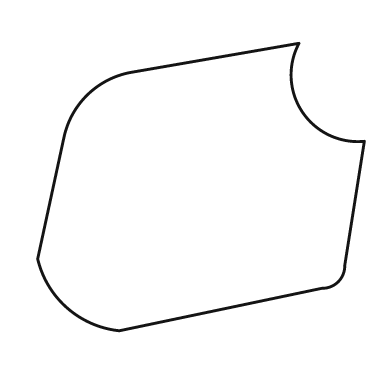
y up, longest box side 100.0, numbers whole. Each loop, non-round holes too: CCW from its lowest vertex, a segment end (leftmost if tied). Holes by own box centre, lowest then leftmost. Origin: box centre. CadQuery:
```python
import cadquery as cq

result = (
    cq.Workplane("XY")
    .moveTo(-25.0, -44.0)
    .lineTo(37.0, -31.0)
    .threePointArc((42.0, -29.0), (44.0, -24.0))
    .lineTo(50.0, 14.0)
    .threePointArc((31.0, 23.0), (30.0, 44.0))
    .lineTo(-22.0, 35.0)
    .threePointArc((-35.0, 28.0), (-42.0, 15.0))
    .lineTo(-50.0, -22.0)
    .threePointArc((-41.0, -37.0), (-25.0, -44.0))
    .close()
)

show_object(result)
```